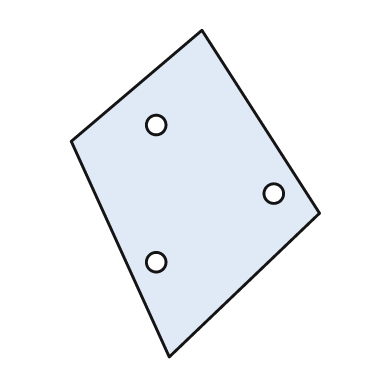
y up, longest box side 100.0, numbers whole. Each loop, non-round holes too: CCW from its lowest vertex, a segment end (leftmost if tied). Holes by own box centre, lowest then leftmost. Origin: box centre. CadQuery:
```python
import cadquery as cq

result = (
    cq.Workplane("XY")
    .moveTo(-8.0, -50.0)
    .lineTo(38.0, -6.0)
    .lineTo(2.0, 50.0)
    .lineTo(-38.0, 16.0)
    .close()
    .moveTo(-12.0, -21.0)
    .circle(3.0)
    .moveTo(24.0, 0.0)
    .circle(3.0)
    .moveTo(-12.0, 21.0)
    .circle(3.0)
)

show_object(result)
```